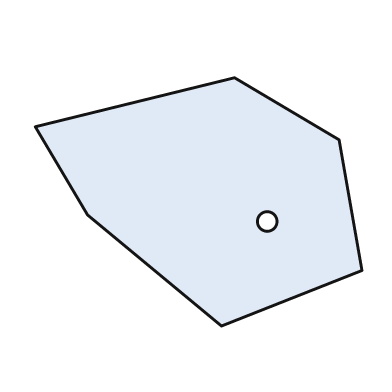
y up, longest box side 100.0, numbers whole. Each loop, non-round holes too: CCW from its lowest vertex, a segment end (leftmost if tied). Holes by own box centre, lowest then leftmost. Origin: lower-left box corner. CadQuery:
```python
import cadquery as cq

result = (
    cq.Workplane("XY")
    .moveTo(57.0, 0.0)
    .lineTo(100.0, 17.0)
    .lineTo(93.0, 57.0)
    .lineTo(61.0, 76.0)
    .lineTo(0.0, 61.0)
    .lineTo(16.0, 34.0)
    .close()
    .moveTo(71.0, 32.0)
    .circle(3.0)
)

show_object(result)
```